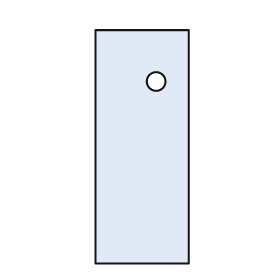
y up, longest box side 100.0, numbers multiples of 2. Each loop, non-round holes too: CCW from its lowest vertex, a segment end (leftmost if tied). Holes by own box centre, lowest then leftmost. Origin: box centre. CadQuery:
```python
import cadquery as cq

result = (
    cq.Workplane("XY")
    .moveTo(-20.0, -50.0)
    .lineTo(20.0, -50.0)
    .lineTo(20.0, 50.0)
    .lineTo(-20.0, 50.0)
    .close()
    .moveTo(6.0, 28.0)
    .circle(4.0)
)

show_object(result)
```